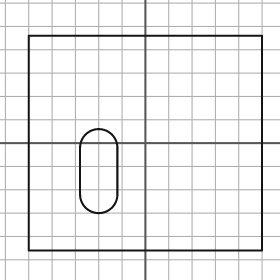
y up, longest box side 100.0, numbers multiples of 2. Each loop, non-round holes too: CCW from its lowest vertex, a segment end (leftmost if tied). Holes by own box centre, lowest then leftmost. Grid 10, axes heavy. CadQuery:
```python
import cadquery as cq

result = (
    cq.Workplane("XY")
    .moveTo(-50.0, -46.0)
    .lineTo(50.0, -46.0)
    .lineTo(50.0, 46.0)
    .lineTo(-50.0, 46.0)
    .close()
    .moveTo(-28.0, -22.0)
    .threePointArc((-20.0, -30.0), (-12.0, -22.0))
    .lineTo(-12.0, -2.0)
    .threePointArc((-20.0, 6.0), (-28.0, -2.0))
    .close()
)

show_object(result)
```